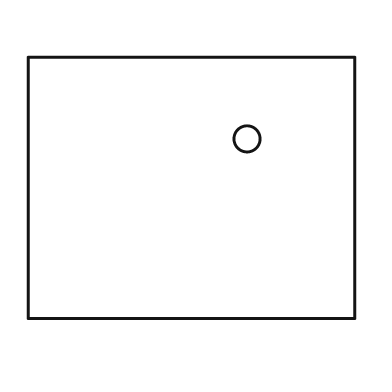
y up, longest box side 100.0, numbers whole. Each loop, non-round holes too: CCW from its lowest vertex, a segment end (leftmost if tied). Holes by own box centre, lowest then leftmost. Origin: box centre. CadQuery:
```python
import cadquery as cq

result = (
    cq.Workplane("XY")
    .moveTo(-50.0, -40.0)
    .lineTo(50.0, -40.0)
    .lineTo(50.0, 40.0)
    .lineTo(-50.0, 40.0)
    .close()
    .moveTo(17.0, 15.0)
    .circle(4.0)
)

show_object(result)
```